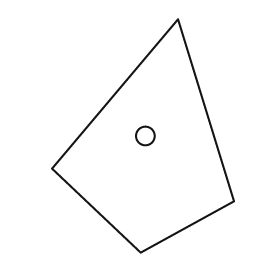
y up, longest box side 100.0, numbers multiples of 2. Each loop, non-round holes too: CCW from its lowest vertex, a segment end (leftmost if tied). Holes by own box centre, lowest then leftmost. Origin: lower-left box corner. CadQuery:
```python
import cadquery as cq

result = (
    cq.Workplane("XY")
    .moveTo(38.0, 0.0)
    .lineTo(78.0, 22.0)
    .lineTo(54.0, 100.0)
    .lineTo(0.0, 36.0)
    .close()
    .moveTo(40.0, 50.0)
    .circle(4.0)
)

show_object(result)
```